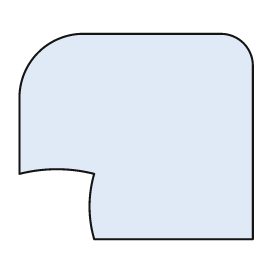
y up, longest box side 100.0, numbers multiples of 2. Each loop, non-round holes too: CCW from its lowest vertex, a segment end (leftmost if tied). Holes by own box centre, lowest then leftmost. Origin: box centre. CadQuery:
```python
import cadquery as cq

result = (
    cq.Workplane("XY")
    .moveTo(-18.0, -44.0)
    .lineTo(50.0, -44.0)
    .lineTo(50.0, 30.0)
    .threePointArc((46.0, 40.0), (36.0, 44.0))
    .lineTo(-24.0, 44.0)
    .threePointArc((-42.0, 36.0), (-50.0, 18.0))
    .lineTo(-50.0, -16.0)
    .threePointArc((-34.0, -14.0), (-18.0, -16.0))
    .threePointArc((-20.0, -30.0), (-18.0, -44.0))
    .close()
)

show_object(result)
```